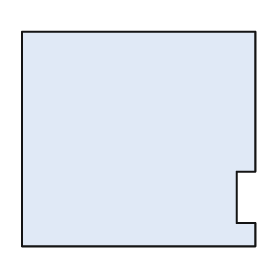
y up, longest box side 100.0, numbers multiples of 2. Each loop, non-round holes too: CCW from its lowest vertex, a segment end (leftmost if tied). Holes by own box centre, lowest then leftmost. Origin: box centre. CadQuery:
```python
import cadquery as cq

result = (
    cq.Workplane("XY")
    .moveTo(-50.0, -46.0)
    .lineTo(50.0, -46.0)
    .lineTo(50.0, -36.0)
    .lineTo(42.0, -36.0)
    .lineTo(42.0, -14.0)
    .lineTo(50.0, -14.0)
    .lineTo(50.0, 46.0)
    .lineTo(-50.0, 46.0)
    .close()
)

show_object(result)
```